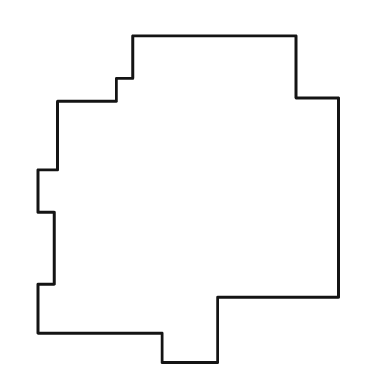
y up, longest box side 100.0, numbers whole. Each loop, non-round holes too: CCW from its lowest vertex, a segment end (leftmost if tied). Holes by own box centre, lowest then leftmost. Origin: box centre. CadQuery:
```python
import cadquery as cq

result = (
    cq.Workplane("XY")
    .moveTo(-8.0, -50.0)
    .lineTo(9.0, -50.0)
    .lineTo(9.0, -30.0)
    .lineTo(46.0, -30.0)
    .lineTo(46.0, 31.0)
    .lineTo(33.0, 31.0)
    .lineTo(33.0, 50.0)
    .lineTo(-17.0, 50.0)
    .lineTo(-17.0, 37.0)
    .lineTo(-22.0, 37.0)
    .lineTo(-22.0, 30.0)
    .lineTo(-40.0, 30.0)
    .lineTo(-40.0, 9.0)
    .lineTo(-46.0, 9.0)
    .lineTo(-46.0, -4.0)
    .lineTo(-41.0, -4.0)
    .lineTo(-41.0, -26.0)
    .lineTo(-46.0, -26.0)
    .lineTo(-46.0, -41.0)
    .lineTo(-8.0, -41.0)
    .close()
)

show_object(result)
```